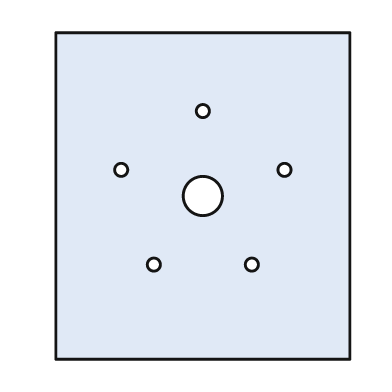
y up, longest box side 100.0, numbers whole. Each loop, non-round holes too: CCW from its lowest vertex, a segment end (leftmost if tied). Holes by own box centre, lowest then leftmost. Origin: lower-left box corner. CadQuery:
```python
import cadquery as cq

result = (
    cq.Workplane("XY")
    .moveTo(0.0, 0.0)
    .lineTo(90.0, 0.0)
    .lineTo(90.0, 100.0)
    .lineTo(0.0, 100.0)
    .close()
    .moveTo(30.0, 29.0)
    .circle(2.0)
    .moveTo(60.0, 29.0)
    .circle(2.0)
    .moveTo(45.0, 50.0)
    .circle(6.0)
    .moveTo(20.0, 58.0)
    .circle(2.0)
    .moveTo(70.0, 58.0)
    .circle(2.0)
    .moveTo(45.0, 76.0)
    .circle(2.0)
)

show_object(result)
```